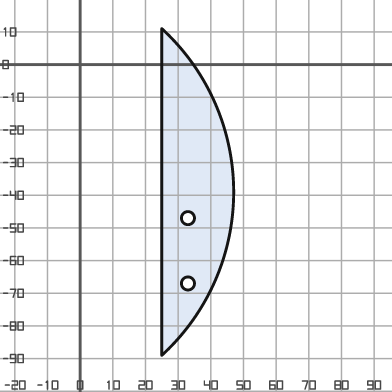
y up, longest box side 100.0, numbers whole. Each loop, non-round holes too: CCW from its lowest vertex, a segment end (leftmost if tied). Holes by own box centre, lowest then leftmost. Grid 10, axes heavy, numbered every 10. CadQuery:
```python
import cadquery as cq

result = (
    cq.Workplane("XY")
    .moveTo(25.0, -89.0)
    .threePointArc((47.0, -39.0), (25.0, 11.0))
    .close()
    .moveTo(33.0, -67.0)
    .circle(2.0)
    .moveTo(33.0, -47.0)
    .circle(2.0)
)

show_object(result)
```